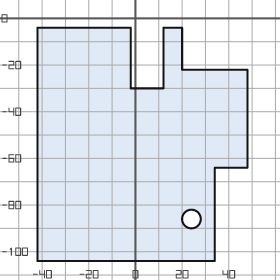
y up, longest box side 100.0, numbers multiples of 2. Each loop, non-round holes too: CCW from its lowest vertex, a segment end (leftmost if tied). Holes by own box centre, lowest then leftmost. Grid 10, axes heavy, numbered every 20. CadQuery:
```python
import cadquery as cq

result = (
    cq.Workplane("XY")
    .moveTo(-42.0, -104.0)
    .lineTo(34.0, -104.0)
    .lineTo(34.0, -64.0)
    .lineTo(48.0, -64.0)
    .lineTo(48.0, -22.0)
    .lineTo(20.0, -22.0)
    .lineTo(20.0, -4.0)
    .lineTo(12.0, -4.0)
    .lineTo(12.0, -30.0)
    .lineTo(-2.0, -30.0)
    .lineTo(-2.0, -4.0)
    .lineTo(-42.0, -4.0)
    .close()
    .moveTo(24.0, -86.0)
    .circle(4.0)
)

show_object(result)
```